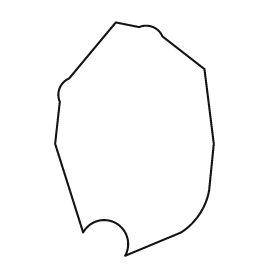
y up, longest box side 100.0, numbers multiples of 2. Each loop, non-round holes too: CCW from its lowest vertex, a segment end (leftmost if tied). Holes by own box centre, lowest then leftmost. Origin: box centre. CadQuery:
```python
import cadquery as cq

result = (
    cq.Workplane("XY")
    .moveTo(-4.0, -50.0)
    .lineTo(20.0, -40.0)
    .threePointArc((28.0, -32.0), (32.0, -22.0))
    .lineTo(34.0, -2.0)
    .lineTo(30.0, 30.0)
    .lineTo(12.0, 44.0)
    .threePointArc((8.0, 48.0), (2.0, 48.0))
    .lineTo(-8.0, 50.0)
    .lineTo(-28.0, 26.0)
    .threePointArc((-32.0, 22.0), (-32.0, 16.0))
    .lineTo(-34.0, -2.0)
    .lineTo(-22.0, -40.0)
    .threePointArc((-8.0, -36.0), (-4.0, -50.0))
    .close()
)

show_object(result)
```